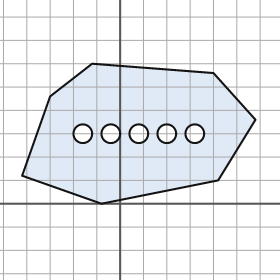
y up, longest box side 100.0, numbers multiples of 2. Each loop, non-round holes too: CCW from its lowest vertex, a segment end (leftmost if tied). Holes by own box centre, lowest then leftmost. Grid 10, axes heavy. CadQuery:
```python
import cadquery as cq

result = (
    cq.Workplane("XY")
    .moveTo(-8.0, 0.0)
    .lineTo(42.0, 10.0)
    .lineTo(58.0, 36.0)
    .lineTo(40.0, 56.0)
    .lineTo(-12.0, 60.0)
    .lineTo(-30.0, 46.0)
    .lineTo(-42.0, 12.0)
    .close()
    .moveTo(-16.0, 30.0)
    .circle(4.0)
    .moveTo(-4.0, 30.0)
    .circle(4.0)
    .moveTo(8.0, 30.0)
    .circle(4.0)
    .moveTo(20.0, 30.0)
    .circle(4.0)
    .moveTo(32.0, 30.0)
    .circle(4.0)
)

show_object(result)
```